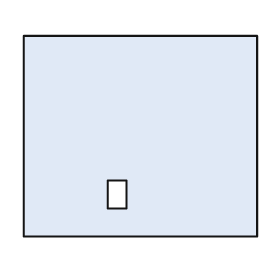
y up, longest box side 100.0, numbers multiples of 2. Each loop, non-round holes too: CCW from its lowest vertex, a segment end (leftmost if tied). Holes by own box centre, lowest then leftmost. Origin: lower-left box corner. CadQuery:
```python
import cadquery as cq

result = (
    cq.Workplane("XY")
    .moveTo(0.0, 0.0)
    .lineTo(100.0, 0.0)
    .lineTo(100.0, 86.0)
    .lineTo(0.0, 86.0)
    .close()
    .moveTo(36.0, 12.0)
    .lineTo(44.0, 12.0)
    .lineTo(44.0, 24.0)
    .lineTo(36.0, 24.0)
    .close()
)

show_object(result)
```